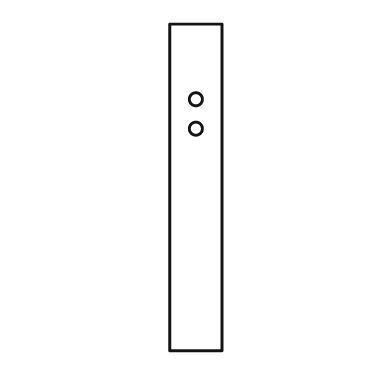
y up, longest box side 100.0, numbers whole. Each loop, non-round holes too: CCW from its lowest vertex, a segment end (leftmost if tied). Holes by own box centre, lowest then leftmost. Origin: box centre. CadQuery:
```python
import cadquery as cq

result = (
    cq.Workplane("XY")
    .moveTo(-8.0, -50.0)
    .lineTo(8.0, -50.0)
    .lineTo(8.0, 50.0)
    .lineTo(-8.0, 50.0)
    .close()
    .moveTo(0.0, 18.0)
    .circle(2.0)
    .moveTo(0.0, 27.0)
    .circle(2.0)
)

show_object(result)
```